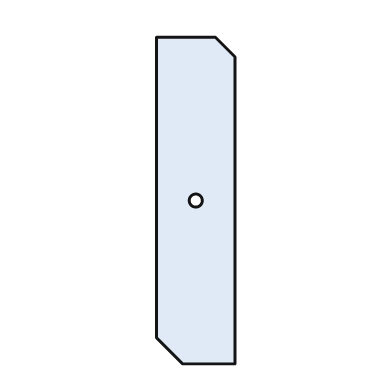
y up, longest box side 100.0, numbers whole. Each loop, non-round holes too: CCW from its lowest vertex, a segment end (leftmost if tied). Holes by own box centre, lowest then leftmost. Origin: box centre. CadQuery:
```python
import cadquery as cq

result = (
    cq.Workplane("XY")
    .moveTo(-4.0, -50.0)
    .lineTo(12.0, -50.0)
    .lineTo(12.0, 44.0)
    .lineTo(6.0, 50.0)
    .lineTo(-12.0, 50.0)
    .lineTo(-12.0, -42.0)
    .close()
    .moveTo(0.0, 0.0)
    .circle(2.0)
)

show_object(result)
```